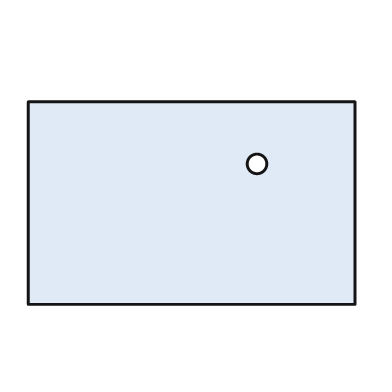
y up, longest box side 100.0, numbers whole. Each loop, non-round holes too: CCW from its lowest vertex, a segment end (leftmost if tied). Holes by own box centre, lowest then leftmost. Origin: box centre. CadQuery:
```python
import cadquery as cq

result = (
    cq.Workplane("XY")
    .moveTo(-50.0, -31.0)
    .lineTo(50.0, -31.0)
    .lineTo(50.0, 31.0)
    .lineTo(-50.0, 31.0)
    .close()
    .moveTo(20.0, 12.0)
    .circle(3.0)
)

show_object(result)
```